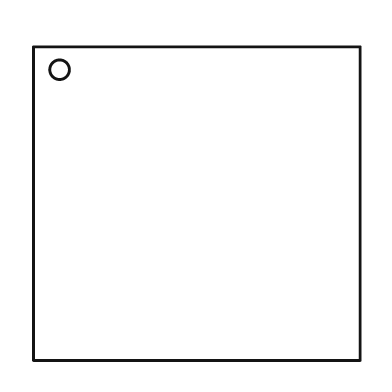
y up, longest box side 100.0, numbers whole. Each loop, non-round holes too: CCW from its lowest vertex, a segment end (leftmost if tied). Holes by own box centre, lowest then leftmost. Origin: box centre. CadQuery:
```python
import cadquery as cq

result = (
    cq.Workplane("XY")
    .moveTo(-50.0, -48.0)
    .lineTo(50.0, -48.0)
    .lineTo(50.0, 48.0)
    .lineTo(-50.0, 48.0)
    .close()
    .moveTo(-42.0, 41.0)
    .circle(3.0)
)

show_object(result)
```